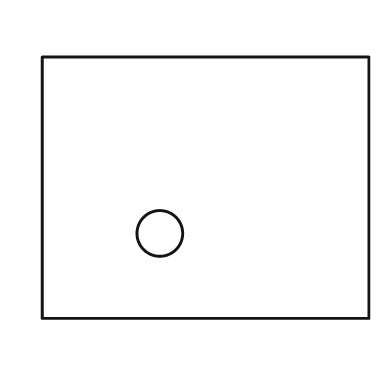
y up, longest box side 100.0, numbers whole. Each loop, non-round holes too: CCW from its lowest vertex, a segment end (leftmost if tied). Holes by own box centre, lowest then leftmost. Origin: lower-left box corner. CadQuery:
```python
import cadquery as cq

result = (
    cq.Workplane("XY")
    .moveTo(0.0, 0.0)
    .lineTo(100.0, 0.0)
    .lineTo(100.0, 80.0)
    .lineTo(0.0, 80.0)
    .close()
    .moveTo(36.0, 26.0)
    .circle(7.0)
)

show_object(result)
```